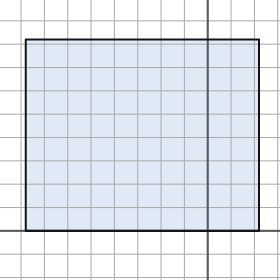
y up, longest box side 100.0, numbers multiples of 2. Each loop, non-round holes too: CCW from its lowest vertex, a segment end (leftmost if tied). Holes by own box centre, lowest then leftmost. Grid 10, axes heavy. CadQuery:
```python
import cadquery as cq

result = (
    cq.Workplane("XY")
    .moveTo(-78.0, 0.0)
    .lineTo(22.0, 0.0)
    .lineTo(22.0, 82.0)
    .lineTo(-78.0, 82.0)
    .close()
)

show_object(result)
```